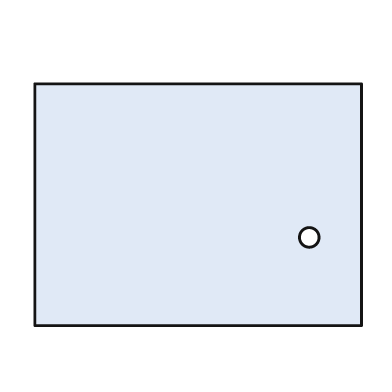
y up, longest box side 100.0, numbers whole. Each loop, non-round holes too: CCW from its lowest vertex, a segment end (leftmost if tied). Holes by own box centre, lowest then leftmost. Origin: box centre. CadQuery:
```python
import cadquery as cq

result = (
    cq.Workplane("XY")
    .moveTo(-50.0, -37.0)
    .lineTo(50.0, -37.0)
    .lineTo(50.0, 37.0)
    .lineTo(-50.0, 37.0)
    .close()
    .moveTo(34.0, -10.0)
    .circle(3.0)
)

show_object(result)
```